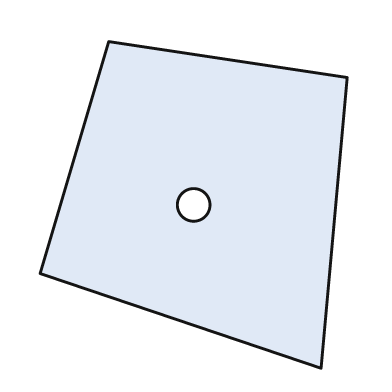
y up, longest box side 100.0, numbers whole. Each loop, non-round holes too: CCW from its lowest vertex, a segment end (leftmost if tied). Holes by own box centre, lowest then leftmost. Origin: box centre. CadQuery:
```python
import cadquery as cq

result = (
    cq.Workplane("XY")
    .moveTo(39.0, -50.0)
    .lineTo(47.0, 39.0)
    .lineTo(-26.0, 50.0)
    .lineTo(-47.0, -21.0)
    .close()
    .moveTo(0.0, 0.0)
    .circle(5.0)
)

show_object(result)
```